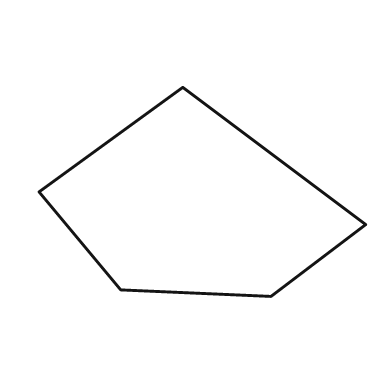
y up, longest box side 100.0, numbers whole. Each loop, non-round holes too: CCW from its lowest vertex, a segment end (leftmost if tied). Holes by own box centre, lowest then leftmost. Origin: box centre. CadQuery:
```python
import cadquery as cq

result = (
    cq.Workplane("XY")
    .moveTo(21.0, -32.0)
    .lineTo(50.0, -10.0)
    .lineTo(-6.0, 32.0)
    .lineTo(-50.0, 0.0)
    .lineTo(-25.0, -30.0)
    .close()
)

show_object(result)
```